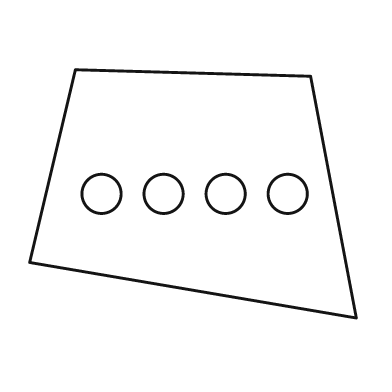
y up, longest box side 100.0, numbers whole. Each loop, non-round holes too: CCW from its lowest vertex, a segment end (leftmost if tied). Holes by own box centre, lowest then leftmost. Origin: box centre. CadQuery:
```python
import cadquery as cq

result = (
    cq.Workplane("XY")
    .moveTo(50.0, -38.0)
    .lineTo(36.0, 36.0)
    .lineTo(-36.0, 38.0)
    .lineTo(-50.0, -21.0)
    .close()
    .moveTo(-28.0, 0.0)
    .circle(6.0)
    .moveTo(-9.0, 0.0)
    .circle(6.0)
    .moveTo(10.0, 0.0)
    .circle(6.0)
    .moveTo(29.0, 0.0)
    .circle(6.0)
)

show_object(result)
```